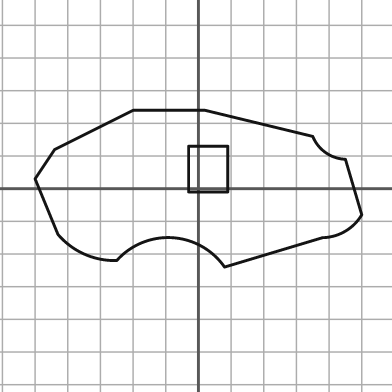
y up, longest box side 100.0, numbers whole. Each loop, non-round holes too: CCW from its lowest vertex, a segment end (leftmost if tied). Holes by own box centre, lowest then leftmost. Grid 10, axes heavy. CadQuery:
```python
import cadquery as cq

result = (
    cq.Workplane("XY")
    .moveTo(8.0, -24.0)
    .lineTo(38.0, -15.0)
    .threePointArc((45.0, -13.0), (50.0, -8.0))
    .lineTo(45.0, 9.0)
    .threePointArc((39.0, 11.0), (35.0, 16.0))
    .lineTo(2.0, 24.0)
    .lineTo(-20.0, 24.0)
    .lineTo(-44.0, 12.0)
    .lineTo(-50.0, 3.0)
    .lineTo(-43.0, -14.0)
    .threePointArc((-35.0, -20.0), (-25.0, -22.0))
    .threePointArc((-8.0, -15.0), (8.0, -24.0))
    .close()
    .moveTo(-3.0, -1.0)
    .lineTo(9.0, -1.0)
    .lineTo(9.0, 13.0)
    .lineTo(-3.0, 13.0)
    .close()
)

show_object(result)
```